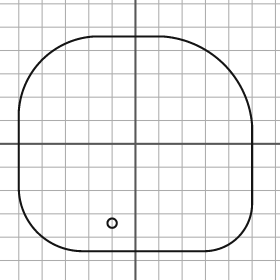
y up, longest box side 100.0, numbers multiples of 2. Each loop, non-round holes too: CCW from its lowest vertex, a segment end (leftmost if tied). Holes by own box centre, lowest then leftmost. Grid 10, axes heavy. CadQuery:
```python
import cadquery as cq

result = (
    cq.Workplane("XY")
    .moveTo(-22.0, -46.0)
    .lineTo(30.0, -46.0)
    .threePointArc((44.0, -40.0), (50.0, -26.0))
    .lineTo(50.0, 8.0)
    .threePointArc((38.0, 34.0), (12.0, 46.0))
    .lineTo(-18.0, 46.0)
    .threePointArc((-40.0, 36.0), (-50.0, 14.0))
    .lineTo(-50.0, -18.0)
    .threePointArc((-42.0, -38.0), (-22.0, -46.0))
    .close()
    .moveTo(-10.0, -34.0)
    .circle(2.0)
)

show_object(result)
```